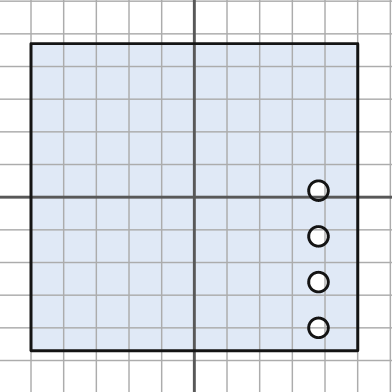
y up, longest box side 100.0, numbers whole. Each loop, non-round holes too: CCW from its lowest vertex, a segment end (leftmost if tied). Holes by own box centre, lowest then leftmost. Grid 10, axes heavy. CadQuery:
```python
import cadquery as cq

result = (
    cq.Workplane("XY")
    .moveTo(-50.0, -47.0)
    .lineTo(50.0, -47.0)
    .lineTo(50.0, 47.0)
    .lineTo(-50.0, 47.0)
    .close()
    .moveTo(38.0, -40.0)
    .circle(3.0)
    .moveTo(38.0, -26.0)
    .circle(3.0)
    .moveTo(38.0, -12.0)
    .circle(3.0)
    .moveTo(38.0, 2.0)
    .circle(3.0)
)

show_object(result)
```